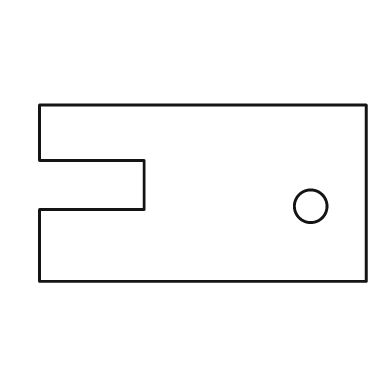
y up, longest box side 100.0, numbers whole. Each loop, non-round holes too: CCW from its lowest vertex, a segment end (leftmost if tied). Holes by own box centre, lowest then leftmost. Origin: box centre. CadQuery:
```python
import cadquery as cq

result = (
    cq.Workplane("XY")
    .moveTo(-50.0, -27.0)
    .lineTo(50.0, -27.0)
    .lineTo(50.0, 27.0)
    .lineTo(-50.0, 27.0)
    .lineTo(-50.0, 10.0)
    .lineTo(-18.0, 10.0)
    .lineTo(-18.0, -5.0)
    .lineTo(-50.0, -5.0)
    .close()
    .moveTo(33.0, -4.0)
    .circle(5.0)
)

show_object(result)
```